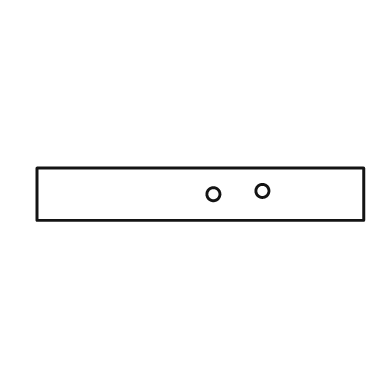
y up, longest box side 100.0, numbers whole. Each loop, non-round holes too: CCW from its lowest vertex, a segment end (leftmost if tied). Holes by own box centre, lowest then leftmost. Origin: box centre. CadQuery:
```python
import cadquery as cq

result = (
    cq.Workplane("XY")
    .moveTo(-50.0, -8.0)
    .lineTo(50.0, -8.0)
    .lineTo(50.0, 8.0)
    .lineTo(-50.0, 8.0)
    .close()
    .moveTo(4.0, 0.0)
    .circle(2.0)
    .moveTo(19.0, 1.0)
    .circle(2.0)
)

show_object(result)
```